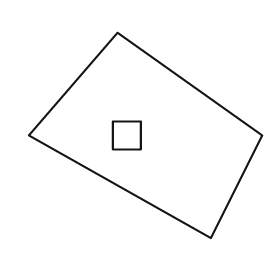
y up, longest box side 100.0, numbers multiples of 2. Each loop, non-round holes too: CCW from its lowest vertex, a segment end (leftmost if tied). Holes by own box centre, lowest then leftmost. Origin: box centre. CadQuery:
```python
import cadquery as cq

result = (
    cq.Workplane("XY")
    .moveTo(28.0, -44.0)
    .lineTo(50.0, 0.0)
    .lineTo(-12.0, 44.0)
    .lineTo(-50.0, 0.0)
    .close()
    .moveTo(-14.0, -6.0)
    .lineTo(-2.0, -6.0)
    .lineTo(-2.0, 6.0)
    .lineTo(-14.0, 6.0)
    .close()
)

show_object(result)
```